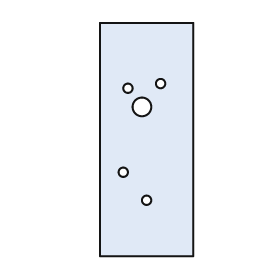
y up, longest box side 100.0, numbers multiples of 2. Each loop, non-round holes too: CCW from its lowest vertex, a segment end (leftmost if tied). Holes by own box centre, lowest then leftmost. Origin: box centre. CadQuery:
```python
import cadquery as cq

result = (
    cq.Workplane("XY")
    .moveTo(-20.0, -50.0)
    .lineTo(20.0, -50.0)
    .lineTo(20.0, 50.0)
    .lineTo(-20.0, 50.0)
    .close()
    .moveTo(0.0, -26.0)
    .circle(2.0)
    .moveTo(-10.0, -14.0)
    .circle(2.0)
    .moveTo(-2.0, 14.0)
    .circle(4.0)
    .moveTo(-8.0, 22.0)
    .circle(2.0)
    .moveTo(6.0, 24.0)
    .circle(2.0)
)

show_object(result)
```